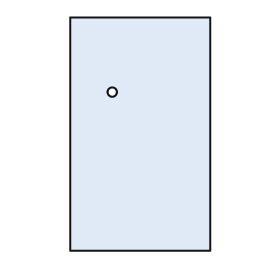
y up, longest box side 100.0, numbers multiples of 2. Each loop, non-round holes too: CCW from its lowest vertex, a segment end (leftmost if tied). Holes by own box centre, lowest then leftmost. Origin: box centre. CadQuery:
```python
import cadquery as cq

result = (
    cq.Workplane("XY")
    .moveTo(-30.0, -50.0)
    .lineTo(30.0, -50.0)
    .lineTo(30.0, 50.0)
    .lineTo(-30.0, 50.0)
    .close()
    .moveTo(-12.0, 18.0)
    .circle(2.0)
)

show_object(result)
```